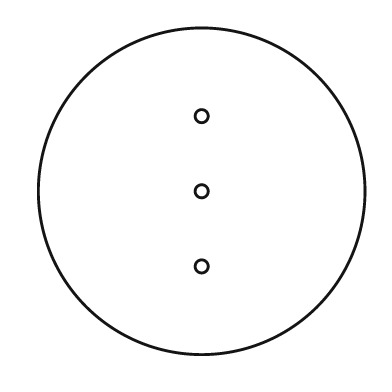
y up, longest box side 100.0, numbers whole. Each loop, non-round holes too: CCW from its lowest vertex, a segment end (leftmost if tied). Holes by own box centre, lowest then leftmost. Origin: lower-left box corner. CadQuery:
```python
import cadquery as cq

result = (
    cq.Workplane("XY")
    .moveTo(50.0, 50.0)
    .circle(50.0)
    .moveTo(50.0, 27.0)
    .circle(2.0)
    .moveTo(50.0, 50.0)
    .circle(2.0)
    .moveTo(50.0, 73.0)
    .circle(2.0)
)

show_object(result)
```